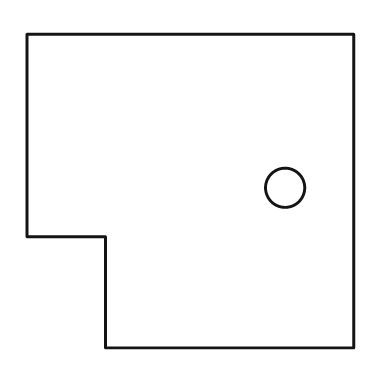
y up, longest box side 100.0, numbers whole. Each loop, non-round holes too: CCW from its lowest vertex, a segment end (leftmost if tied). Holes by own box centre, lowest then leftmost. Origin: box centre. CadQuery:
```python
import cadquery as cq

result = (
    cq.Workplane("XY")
    .moveTo(-26.0, -48.0)
    .lineTo(50.0, -48.0)
    .lineTo(50.0, 48.0)
    .lineTo(-50.0, 48.0)
    .lineTo(-50.0, -14.0)
    .lineTo(-26.0, -14.0)
    .close()
    .moveTo(29.0, 1.0)
    .circle(6.0)
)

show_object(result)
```